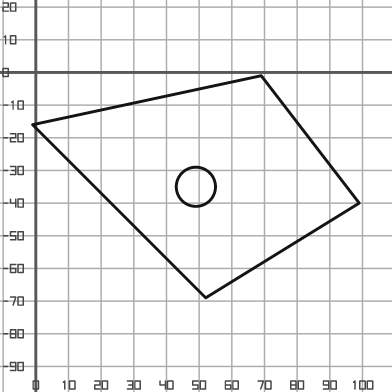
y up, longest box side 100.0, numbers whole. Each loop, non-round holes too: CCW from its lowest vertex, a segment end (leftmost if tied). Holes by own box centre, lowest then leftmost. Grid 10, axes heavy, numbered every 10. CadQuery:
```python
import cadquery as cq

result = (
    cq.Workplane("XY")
    .moveTo(52.0, -69.0)
    .lineTo(99.0, -40.0)
    .lineTo(69.0, -1.0)
    .lineTo(-1.0, -16.0)
    .close()
    .moveTo(49.0, -35.0)
    .circle(6.0)
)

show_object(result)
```